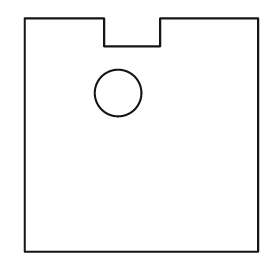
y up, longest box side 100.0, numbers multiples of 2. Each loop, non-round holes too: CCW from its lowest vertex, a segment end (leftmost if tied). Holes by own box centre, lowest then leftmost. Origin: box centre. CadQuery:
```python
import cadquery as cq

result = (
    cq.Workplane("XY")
    .moveTo(-50.0, -50.0)
    .lineTo(50.0, -50.0)
    .lineTo(50.0, 50.0)
    .lineTo(8.0, 50.0)
    .lineTo(8.0, 38.0)
    .lineTo(-16.0, 38.0)
    .lineTo(-16.0, 50.0)
    .lineTo(-50.0, 50.0)
    .close()
    .moveTo(-10.0, 18.0)
    .circle(10.0)
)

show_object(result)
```